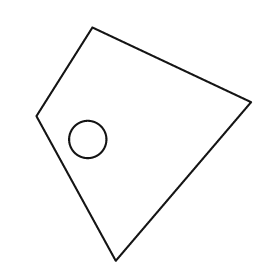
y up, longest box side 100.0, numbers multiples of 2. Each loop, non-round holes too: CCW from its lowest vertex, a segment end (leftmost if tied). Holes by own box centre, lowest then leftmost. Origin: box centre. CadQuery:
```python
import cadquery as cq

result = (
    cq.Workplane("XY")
    .moveTo(-12.0, -50.0)
    .lineTo(46.0, 18.0)
    .lineTo(-22.0, 50.0)
    .lineTo(-46.0, 12.0)
    .close()
    .moveTo(-24.0, 2.0)
    .circle(8.0)
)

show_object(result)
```